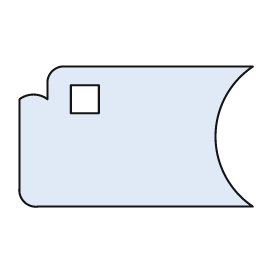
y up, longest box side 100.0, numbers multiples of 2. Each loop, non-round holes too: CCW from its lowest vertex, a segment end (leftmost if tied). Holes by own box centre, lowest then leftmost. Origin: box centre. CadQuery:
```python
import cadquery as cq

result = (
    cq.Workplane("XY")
    .moveTo(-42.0, -30.0)
    .lineTo(50.0, -30.0)
    .threePointArc((34.0, 0.0), (50.0, 30.0))
    .lineTo(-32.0, 30.0)
    .threePointArc((-36.0, 28.0), (-38.0, 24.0))
    .lineTo(-38.0, 16.0)
    .threePointArc((-44.0, 18.0), (-50.0, 16.0))
    .lineTo(-50.0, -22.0)
    .threePointArc((-48.0, -28.0), (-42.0, -30.0))
    .close()
    .moveTo(-28.0, 10.0)
    .lineTo(-16.0, 10.0)
    .lineTo(-16.0, 22.0)
    .lineTo(-28.0, 22.0)
    .close()
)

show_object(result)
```